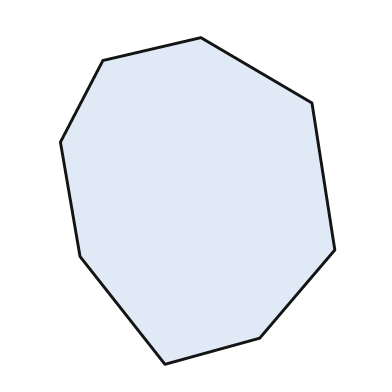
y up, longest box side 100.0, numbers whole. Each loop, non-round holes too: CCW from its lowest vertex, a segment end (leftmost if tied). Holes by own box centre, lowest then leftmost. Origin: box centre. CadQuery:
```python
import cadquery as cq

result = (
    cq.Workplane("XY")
    .moveTo(-10.0, -50.0)
    .lineTo(19.0, -42.0)
    .lineTo(42.0, -15.0)
    .lineTo(35.0, 30.0)
    .lineTo(1.0, 50.0)
    .lineTo(-29.0, 43.0)
    .lineTo(-42.0, 18.0)
    .lineTo(-36.0, -17.0)
    .close()
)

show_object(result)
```